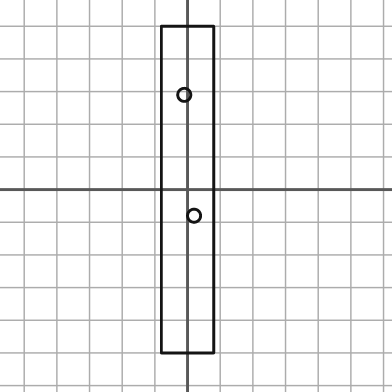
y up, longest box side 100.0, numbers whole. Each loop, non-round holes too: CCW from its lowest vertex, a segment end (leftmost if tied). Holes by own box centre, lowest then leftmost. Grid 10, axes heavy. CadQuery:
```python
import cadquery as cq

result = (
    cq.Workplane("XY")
    .moveTo(-8.0, -50.0)
    .lineTo(8.0, -50.0)
    .lineTo(8.0, 50.0)
    .lineTo(-8.0, 50.0)
    .close()
    .moveTo(2.0, -8.0)
    .circle(2.0)
    .moveTo(-1.0, 29.0)
    .circle(2.0)
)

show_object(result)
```